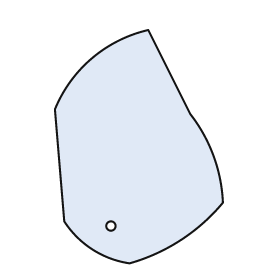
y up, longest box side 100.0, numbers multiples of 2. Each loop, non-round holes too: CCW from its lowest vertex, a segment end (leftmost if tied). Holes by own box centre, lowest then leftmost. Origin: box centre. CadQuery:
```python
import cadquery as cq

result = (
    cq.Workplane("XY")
    .moveTo(-4.0, -50.0)
    .threePointArc((18.0, -40.0), (36.0, -24.0))
    .threePointArc((32.0, -4.0), (22.0, 14.0))
    .lineTo(4.0, 50.0)
    .threePointArc((-20.0, 38.0), (-36.0, 16.0))
    .lineTo(-32.0, -32.0)
    .threePointArc((-20.0, -44.0), (-4.0, -50.0))
    .close()
    .moveTo(-12.0, -34.0)
    .circle(2.0)
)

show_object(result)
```